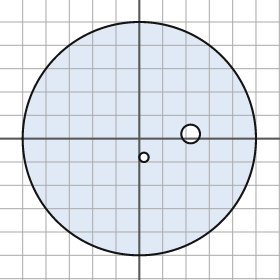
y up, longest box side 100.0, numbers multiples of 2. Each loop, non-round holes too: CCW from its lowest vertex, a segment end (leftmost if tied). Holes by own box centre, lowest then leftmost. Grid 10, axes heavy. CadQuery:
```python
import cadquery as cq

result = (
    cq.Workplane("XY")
    .moveTo(0.0, 0.0)
    .circle(50.0)
    .moveTo(2.0, -8.0)
    .circle(2.0)
    .moveTo(22.0, 2.0)
    .circle(4.0)
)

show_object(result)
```